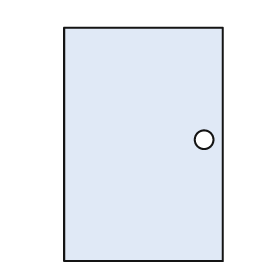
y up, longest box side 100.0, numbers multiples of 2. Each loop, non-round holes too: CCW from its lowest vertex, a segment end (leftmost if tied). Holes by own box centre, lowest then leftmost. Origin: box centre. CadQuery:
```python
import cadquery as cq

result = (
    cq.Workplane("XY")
    .moveTo(-34.0, -50.0)
    .lineTo(34.0, -50.0)
    .lineTo(34.0, 50.0)
    .lineTo(-34.0, 50.0)
    .close()
    .moveTo(26.0, 2.0)
    .circle(4.0)
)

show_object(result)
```